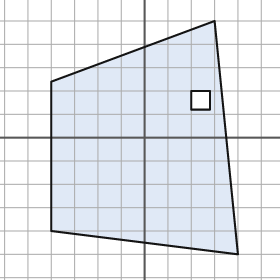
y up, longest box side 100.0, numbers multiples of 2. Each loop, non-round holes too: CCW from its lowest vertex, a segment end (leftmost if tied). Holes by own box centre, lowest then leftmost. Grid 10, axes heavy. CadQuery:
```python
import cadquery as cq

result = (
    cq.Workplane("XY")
    .moveTo(40.0, -50.0)
    .lineTo(30.0, 50.0)
    .lineTo(-40.0, 24.0)
    .lineTo(-40.0, -40.0)
    .close()
    .moveTo(20.0, 12.0)
    .lineTo(28.0, 12.0)
    .lineTo(28.0, 20.0)
    .lineTo(20.0, 20.0)
    .close()
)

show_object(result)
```